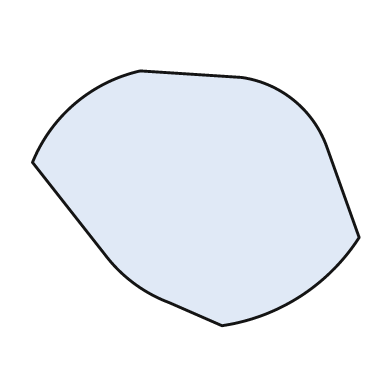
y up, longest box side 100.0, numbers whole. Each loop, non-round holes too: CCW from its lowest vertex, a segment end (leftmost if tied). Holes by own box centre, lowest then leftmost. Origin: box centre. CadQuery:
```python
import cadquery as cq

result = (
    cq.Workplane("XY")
    .moveTo(8.0, -39.0)
    .threePointArc((32.0, -30.0), (50.0, -12.0))
    .lineTo(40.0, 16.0)
    .threePointArc((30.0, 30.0), (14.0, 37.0))
    .lineTo(-17.0, 39.0)
    .threePointArc((-37.0, 29.0), (-50.0, 11.0))
    .lineTo(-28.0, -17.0)
    .threePointArc((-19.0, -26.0), (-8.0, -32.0))
    .close()
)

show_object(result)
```